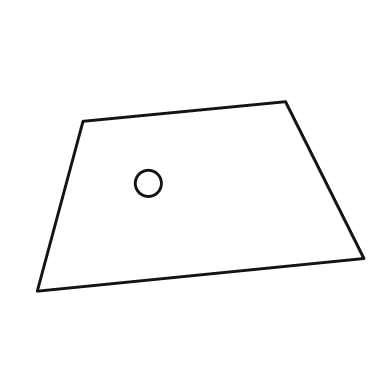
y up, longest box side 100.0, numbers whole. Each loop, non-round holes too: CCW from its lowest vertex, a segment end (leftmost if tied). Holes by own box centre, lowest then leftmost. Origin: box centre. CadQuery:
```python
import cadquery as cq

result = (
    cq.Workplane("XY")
    .moveTo(-50.0, -29.0)
    .lineTo(50.0, -19.0)
    .lineTo(26.0, 29.0)
    .lineTo(-36.0, 23.0)
    .close()
    .moveTo(-16.0, 4.0)
    .circle(4.0)
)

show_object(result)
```